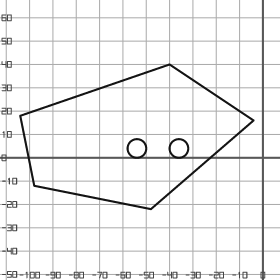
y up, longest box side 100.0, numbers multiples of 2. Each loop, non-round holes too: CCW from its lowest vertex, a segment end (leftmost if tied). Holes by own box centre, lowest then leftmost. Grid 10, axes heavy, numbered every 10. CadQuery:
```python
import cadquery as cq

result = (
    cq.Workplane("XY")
    .moveTo(-48.0, -22.0)
    .lineTo(-4.0, 16.0)
    .lineTo(-40.0, 40.0)
    .lineTo(-104.0, 18.0)
    .lineTo(-98.0, -12.0)
    .close()
    .moveTo(-54.0, 4.0)
    .circle(4.0)
    .moveTo(-36.0, 4.0)
    .circle(4.0)
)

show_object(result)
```